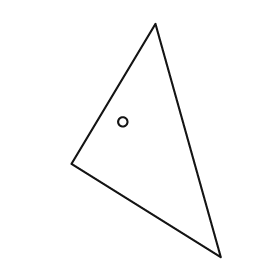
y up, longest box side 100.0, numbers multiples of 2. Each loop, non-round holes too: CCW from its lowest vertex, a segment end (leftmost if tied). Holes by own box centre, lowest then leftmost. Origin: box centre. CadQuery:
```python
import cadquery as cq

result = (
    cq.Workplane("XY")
    .moveTo(32.0, -50.0)
    .lineTo(4.0, 50.0)
    .lineTo(-32.0, -10.0)
    .close()
    .moveTo(-10.0, 8.0)
    .circle(2.0)
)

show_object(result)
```